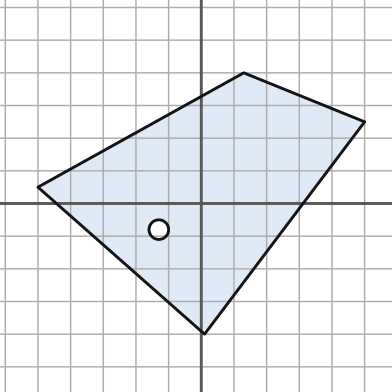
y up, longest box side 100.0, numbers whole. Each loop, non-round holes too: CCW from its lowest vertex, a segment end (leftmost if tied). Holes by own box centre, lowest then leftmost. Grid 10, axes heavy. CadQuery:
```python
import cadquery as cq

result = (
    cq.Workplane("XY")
    .moveTo(1.0, -40.0)
    .lineTo(50.0, 25.0)
    .lineTo(13.0, 40.0)
    .lineTo(-50.0, 5.0)
    .close()
    .moveTo(-13.0, -8.0)
    .circle(3.0)
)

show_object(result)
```